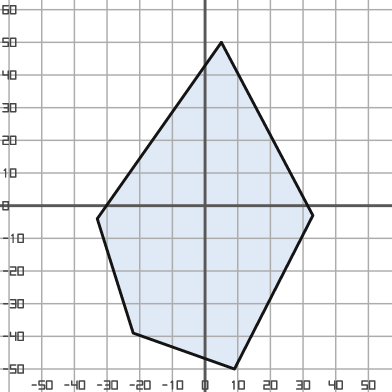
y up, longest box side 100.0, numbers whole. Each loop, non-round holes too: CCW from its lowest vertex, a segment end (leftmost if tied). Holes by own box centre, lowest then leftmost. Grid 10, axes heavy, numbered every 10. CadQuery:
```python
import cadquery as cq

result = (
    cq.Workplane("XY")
    .moveTo(9.0, -50.0)
    .lineTo(33.0, -3.0)
    .lineTo(5.0, 50.0)
    .lineTo(-33.0, -4.0)
    .lineTo(-22.0, -39.0)
    .close()
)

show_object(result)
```